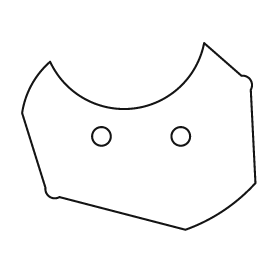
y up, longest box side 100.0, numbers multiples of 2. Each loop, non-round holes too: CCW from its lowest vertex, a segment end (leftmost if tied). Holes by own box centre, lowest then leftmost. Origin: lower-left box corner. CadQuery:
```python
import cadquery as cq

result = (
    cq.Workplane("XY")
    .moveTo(70.0, 0.0)
    .threePointArc((86.0, 8.0), (100.0, 20.0))
    .lineTo(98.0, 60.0)
    .threePointArc((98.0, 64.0), (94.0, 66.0))
    .lineTo(78.0, 80.0)
    .threePointArc((48.0, 52.0), (12.0, 72.0))
    .threePointArc((4.0, 62.0), (0.0, 50.0))
    .lineTo(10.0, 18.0)
    .threePointArc((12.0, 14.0), (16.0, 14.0))
    .close()
    .moveTo(34.0, 40.0)
    .circle(4.0)
    .moveTo(68.0, 40.0)
    .circle(4.0)
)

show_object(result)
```